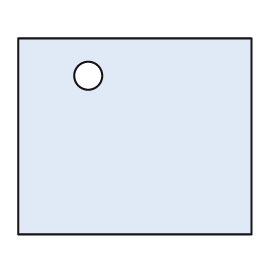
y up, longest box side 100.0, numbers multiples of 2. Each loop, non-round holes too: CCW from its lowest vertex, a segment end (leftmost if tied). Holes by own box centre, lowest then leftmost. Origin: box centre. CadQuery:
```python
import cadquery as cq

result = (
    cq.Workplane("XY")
    .moveTo(-50.0, -42.0)
    .lineTo(50.0, -42.0)
    .lineTo(50.0, 42.0)
    .lineTo(-50.0, 42.0)
    .close()
    .moveTo(-20.0, 26.0)
    .circle(6.0)
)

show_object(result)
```